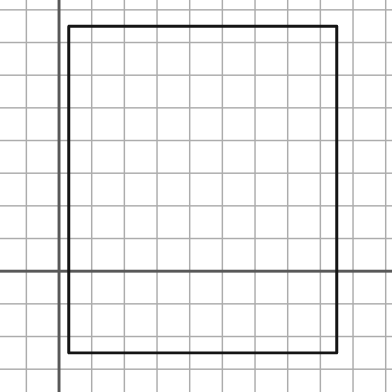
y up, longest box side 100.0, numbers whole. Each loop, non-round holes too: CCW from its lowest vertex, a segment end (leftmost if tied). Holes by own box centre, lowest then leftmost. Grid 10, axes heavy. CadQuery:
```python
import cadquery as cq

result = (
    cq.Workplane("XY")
    .moveTo(3.0, -25.0)
    .lineTo(85.0, -25.0)
    .lineTo(85.0, 75.0)
    .lineTo(3.0, 75.0)
    .close()
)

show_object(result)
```